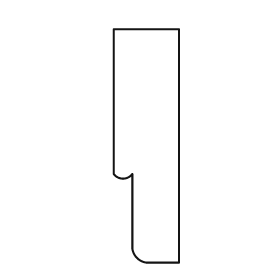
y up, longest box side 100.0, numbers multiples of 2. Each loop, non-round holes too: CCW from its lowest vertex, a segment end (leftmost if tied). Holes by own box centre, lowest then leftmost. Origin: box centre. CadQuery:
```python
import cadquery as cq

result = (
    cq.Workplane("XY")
    .moveTo(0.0, -50.0)
    .lineTo(14.0, -50.0)
    .lineTo(14.0, 50.0)
    .lineTo(-14.0, 50.0)
    .lineTo(-14.0, -12.0)
    .threePointArc((-10.0, -14.0), (-6.0, -12.0))
    .lineTo(-6.0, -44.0)
    .threePointArc((-4.0, -48.0), (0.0, -50.0))
    .close()
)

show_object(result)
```